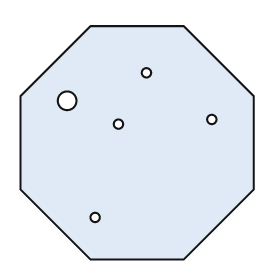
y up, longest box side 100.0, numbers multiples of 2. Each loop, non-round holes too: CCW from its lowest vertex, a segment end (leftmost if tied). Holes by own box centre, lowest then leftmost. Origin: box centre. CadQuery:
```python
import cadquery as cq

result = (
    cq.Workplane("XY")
    .moveTo(-20.0, -50.0)
    .lineTo(20.0, -50.0)
    .lineTo(50.0, -20.0)
    .lineTo(50.0, 20.0)
    .lineTo(20.0, 50.0)
    .lineTo(-20.0, 50.0)
    .lineTo(-50.0, 20.0)
    .lineTo(-50.0, -20.0)
    .close()
    .moveTo(-18.0, -32.0)
    .circle(2.0)
    .moveTo(-8.0, 8.0)
    .circle(2.0)
    .moveTo(32.0, 10.0)
    .circle(2.0)
    .moveTo(-30.0, 18.0)
    .circle(4.0)
    .moveTo(4.0, 30.0)
    .circle(2.0)
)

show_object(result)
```